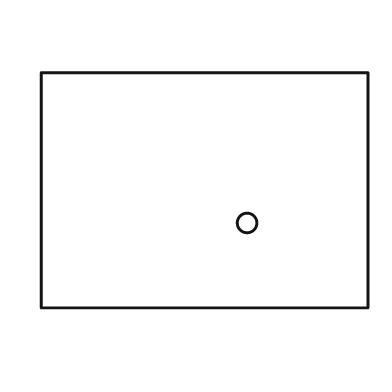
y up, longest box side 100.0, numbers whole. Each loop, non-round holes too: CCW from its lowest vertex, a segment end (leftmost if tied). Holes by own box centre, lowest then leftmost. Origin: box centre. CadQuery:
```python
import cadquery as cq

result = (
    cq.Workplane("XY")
    .moveTo(-50.0, -36.0)
    .lineTo(50.0, -36.0)
    .lineTo(50.0, 36.0)
    .lineTo(-50.0, 36.0)
    .close()
    .moveTo(13.0, -10.0)
    .circle(3.0)
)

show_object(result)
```